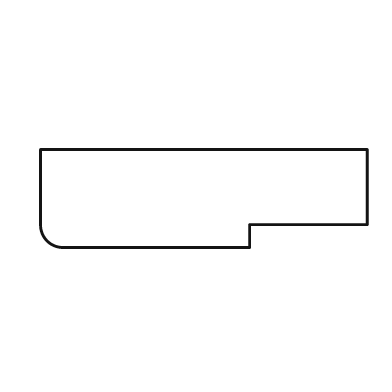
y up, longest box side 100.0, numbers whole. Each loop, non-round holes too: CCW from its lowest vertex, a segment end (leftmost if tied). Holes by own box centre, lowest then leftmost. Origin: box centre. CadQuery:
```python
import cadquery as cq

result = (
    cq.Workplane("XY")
    .moveTo(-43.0, -15.0)
    .lineTo(14.0, -15.0)
    .lineTo(14.0, -8.0)
    .lineTo(50.0, -8.0)
    .lineTo(50.0, 15.0)
    .lineTo(-50.0, 15.0)
    .lineTo(-50.0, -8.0)
    .threePointArc((-48.0, -13.0), (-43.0, -15.0))
    .close()
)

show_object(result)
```